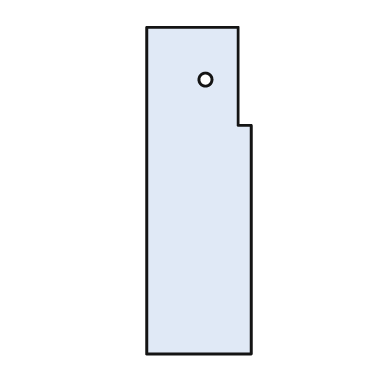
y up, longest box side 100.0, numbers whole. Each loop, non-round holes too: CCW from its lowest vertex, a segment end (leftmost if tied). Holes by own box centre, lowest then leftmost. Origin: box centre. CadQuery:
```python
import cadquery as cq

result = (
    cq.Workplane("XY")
    .moveTo(-16.0, -50.0)
    .lineTo(16.0, -50.0)
    .lineTo(16.0, 20.0)
    .lineTo(12.0, 20.0)
    .lineTo(12.0, 50.0)
    .lineTo(-16.0, 50.0)
    .close()
    .moveTo(2.0, 34.0)
    .circle(2.0)
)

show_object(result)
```